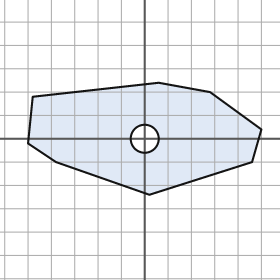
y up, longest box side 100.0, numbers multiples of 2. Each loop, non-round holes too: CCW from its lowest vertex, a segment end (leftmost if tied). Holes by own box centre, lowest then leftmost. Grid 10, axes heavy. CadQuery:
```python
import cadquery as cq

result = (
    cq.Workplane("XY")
    .moveTo(2.0, -24.0)
    .lineTo(46.0, -10.0)
    .lineTo(50.0, 4.0)
    .lineTo(28.0, 20.0)
    .lineTo(6.0, 24.0)
    .lineTo(-48.0, 18.0)
    .lineTo(-50.0, -2.0)
    .lineTo(-38.0, -10.0)
    .close()
    .moveTo(0.0, 0.0)
    .circle(6.0)
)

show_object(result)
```